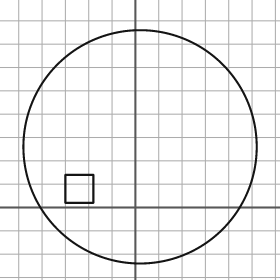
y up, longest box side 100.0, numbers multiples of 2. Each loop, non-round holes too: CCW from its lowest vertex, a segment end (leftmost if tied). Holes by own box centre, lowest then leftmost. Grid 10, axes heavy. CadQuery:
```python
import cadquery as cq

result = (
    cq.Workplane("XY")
    .moveTo(2.0, 26.0)
    .circle(50.0)
    .moveTo(-30.0, 2.0)
    .lineTo(-18.0, 2.0)
    .lineTo(-18.0, 14.0)
    .lineTo(-30.0, 14.0)
    .close()
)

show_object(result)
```